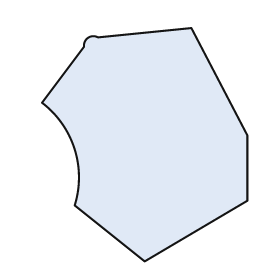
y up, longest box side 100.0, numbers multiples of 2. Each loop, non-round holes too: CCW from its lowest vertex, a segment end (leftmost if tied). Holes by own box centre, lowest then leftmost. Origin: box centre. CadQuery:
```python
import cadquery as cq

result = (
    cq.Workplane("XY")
    .moveTo(0.0, -50.0)
    .lineTo(44.0, -24.0)
    .lineTo(44.0, 4.0)
    .lineTo(20.0, 50.0)
    .lineTo(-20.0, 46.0)
    .threePointArc((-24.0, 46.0), (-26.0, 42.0))
    .lineTo(-44.0, 18.0)
    .threePointArc((-30.0, -2.0), (-30.0, -26.0))
    .close()
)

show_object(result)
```